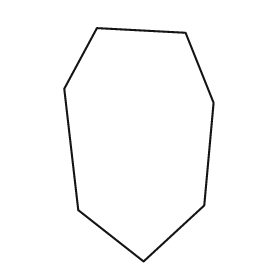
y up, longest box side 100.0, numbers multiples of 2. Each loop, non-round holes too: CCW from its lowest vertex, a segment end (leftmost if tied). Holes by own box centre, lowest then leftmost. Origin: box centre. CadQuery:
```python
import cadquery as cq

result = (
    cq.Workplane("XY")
    .moveTo(2.0, -50.0)
    .lineTo(28.0, -26.0)
    .lineTo(32.0, 18.0)
    .lineTo(20.0, 48.0)
    .lineTo(-18.0, 50.0)
    .lineTo(-32.0, 24.0)
    .lineTo(-26.0, -28.0)
    .close()
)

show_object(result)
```